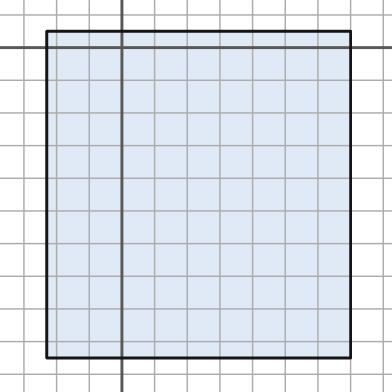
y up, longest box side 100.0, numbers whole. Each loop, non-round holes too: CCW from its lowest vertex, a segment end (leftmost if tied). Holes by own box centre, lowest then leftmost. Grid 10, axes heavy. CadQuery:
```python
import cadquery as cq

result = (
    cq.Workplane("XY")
    .moveTo(-23.0, -95.0)
    .lineTo(70.0, -95.0)
    .lineTo(70.0, 5.0)
    .lineTo(-23.0, 5.0)
    .close()
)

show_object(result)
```